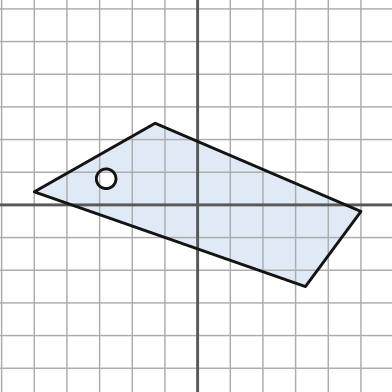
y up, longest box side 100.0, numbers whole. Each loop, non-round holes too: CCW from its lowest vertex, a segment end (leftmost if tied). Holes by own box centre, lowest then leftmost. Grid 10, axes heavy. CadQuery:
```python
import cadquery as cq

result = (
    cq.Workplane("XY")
    .moveTo(33.0, -25.0)
    .lineTo(50.0, -2.0)
    .lineTo(-13.0, 25.0)
    .lineTo(-50.0, 4.0)
    .close()
    .moveTo(-28.0, 8.0)
    .circle(3.0)
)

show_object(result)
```